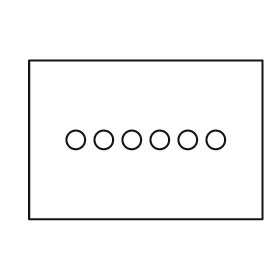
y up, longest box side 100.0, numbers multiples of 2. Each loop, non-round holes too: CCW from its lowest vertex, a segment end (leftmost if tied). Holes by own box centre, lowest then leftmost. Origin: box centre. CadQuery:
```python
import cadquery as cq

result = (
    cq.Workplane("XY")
    .moveTo(-50.0, -34.0)
    .lineTo(50.0, -34.0)
    .lineTo(50.0, 34.0)
    .lineTo(-50.0, 34.0)
    .close()
    .moveTo(-30.0, 0.0)
    .circle(4.0)
    .moveTo(-18.0, 0.0)
    .circle(4.0)
    .moveTo(-6.0, 0.0)
    .circle(4.0)
    .moveTo(6.0, 0.0)
    .circle(4.0)
    .moveTo(18.0, 0.0)
    .circle(4.0)
    .moveTo(30.0, 0.0)
    .circle(4.0)
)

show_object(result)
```